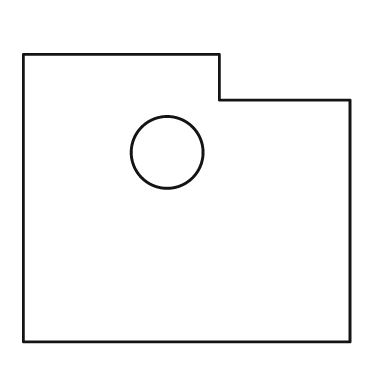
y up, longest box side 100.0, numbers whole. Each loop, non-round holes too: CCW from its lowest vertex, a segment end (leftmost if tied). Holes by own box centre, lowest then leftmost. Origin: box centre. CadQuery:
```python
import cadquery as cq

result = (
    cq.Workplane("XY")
    .moveTo(-50.0, -44.0)
    .lineTo(50.0, -44.0)
    .lineTo(50.0, 30.0)
    .lineTo(10.0, 30.0)
    .lineTo(10.0, 44.0)
    .lineTo(-50.0, 44.0)
    .close()
    .moveTo(-6.0, 14.0)
    .circle(11.0)
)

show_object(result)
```